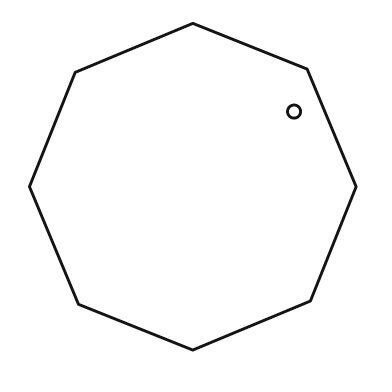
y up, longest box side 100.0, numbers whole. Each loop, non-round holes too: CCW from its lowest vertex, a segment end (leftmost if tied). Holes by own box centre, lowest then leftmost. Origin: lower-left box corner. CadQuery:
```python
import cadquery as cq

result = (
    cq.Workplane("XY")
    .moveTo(50.0, 0.0)
    .lineTo(86.0, 15.0)
    .lineTo(100.0, 50.0)
    .lineTo(85.0, 86.0)
    .lineTo(50.0, 100.0)
    .lineTo(14.0, 85.0)
    .lineTo(0.0, 50.0)
    .lineTo(15.0, 14.0)
    .close()
    .moveTo(81.0, 73.0)
    .circle(2.0)
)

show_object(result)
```